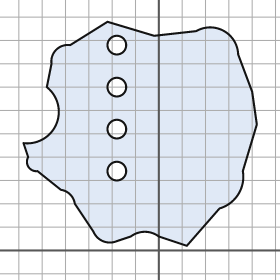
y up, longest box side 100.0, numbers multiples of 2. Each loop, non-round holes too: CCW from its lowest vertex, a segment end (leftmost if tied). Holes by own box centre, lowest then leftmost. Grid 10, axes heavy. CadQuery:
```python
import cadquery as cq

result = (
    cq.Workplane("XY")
    .moveTo(12.0, 2.0)
    .lineTo(26.0, 18.0)
    .threePointArc((34.0, 24.0), (36.0, 34.0))
    .lineTo(42.0, 54.0)
    .lineTo(40.0, 68.0)
    .lineTo(34.0, 84.0)
    .threePointArc((28.0, 94.0), (16.0, 94.0))
    .lineTo(-2.0, 92.0)
    .lineTo(-22.0, 98.0)
    .lineTo(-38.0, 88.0)
    .threePointArc((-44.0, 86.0), (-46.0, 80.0))
    .lineTo(-48.0, 70.0)
    .threePointArc((-44.0, 54.0), (-58.0, 46.0))
    .lineTo(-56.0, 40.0)
    .threePointArc((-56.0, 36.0), (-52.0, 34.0))
    .lineTo(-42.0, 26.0)
    .threePointArc((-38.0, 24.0), (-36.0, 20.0))
    .lineTo(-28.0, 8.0)
    .threePointArc((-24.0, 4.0), (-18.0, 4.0))
    .lineTo(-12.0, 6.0)
    .threePointArc((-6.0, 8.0), (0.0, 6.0))
    .close()
    .moveTo(-18.0, 34.0)
    .circle(4.0)
    .moveTo(-18.0, 52.0)
    .circle(4.0)
    .moveTo(-18.0, 70.0)
    .circle(4.0)
    .moveTo(-18.0, 88.0)
    .circle(4.0)
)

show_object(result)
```